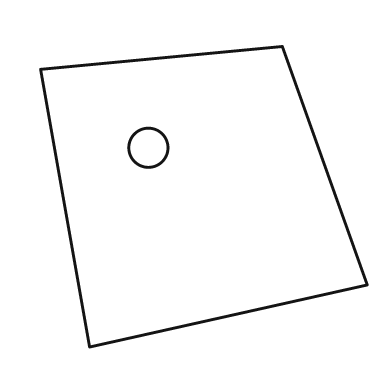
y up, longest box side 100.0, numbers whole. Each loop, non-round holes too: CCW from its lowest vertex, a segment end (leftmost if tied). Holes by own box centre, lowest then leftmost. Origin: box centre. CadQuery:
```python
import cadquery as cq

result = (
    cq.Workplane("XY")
    .moveTo(-35.0, -46.0)
    .lineTo(50.0, -27.0)
    .lineTo(24.0, 46.0)
    .lineTo(-50.0, 39.0)
    .close()
    .moveTo(-17.0, 15.0)
    .circle(6.0)
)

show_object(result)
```